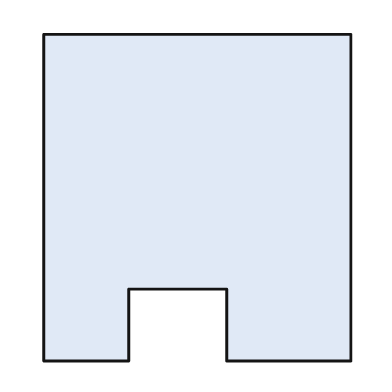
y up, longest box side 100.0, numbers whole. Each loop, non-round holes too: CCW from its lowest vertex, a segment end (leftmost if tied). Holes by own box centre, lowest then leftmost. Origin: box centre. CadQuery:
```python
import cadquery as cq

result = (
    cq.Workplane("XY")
    .moveTo(-47.0, -50.0)
    .lineTo(-21.0, -50.0)
    .lineTo(-21.0, -28.0)
    .lineTo(9.0, -28.0)
    .lineTo(9.0, -50.0)
    .lineTo(47.0, -50.0)
    .lineTo(47.0, 50.0)
    .lineTo(-47.0, 50.0)
    .close()
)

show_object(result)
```